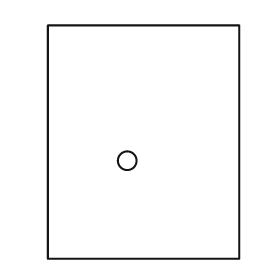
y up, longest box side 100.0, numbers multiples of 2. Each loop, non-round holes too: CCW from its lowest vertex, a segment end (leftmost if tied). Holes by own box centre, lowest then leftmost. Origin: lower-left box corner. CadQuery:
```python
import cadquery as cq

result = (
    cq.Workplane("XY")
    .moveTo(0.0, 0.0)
    .lineTo(82.0, 0.0)
    .lineTo(82.0, 100.0)
    .lineTo(0.0, 100.0)
    .close()
    .moveTo(34.0, 42.0)
    .circle(4.0)
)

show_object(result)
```